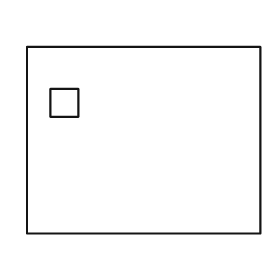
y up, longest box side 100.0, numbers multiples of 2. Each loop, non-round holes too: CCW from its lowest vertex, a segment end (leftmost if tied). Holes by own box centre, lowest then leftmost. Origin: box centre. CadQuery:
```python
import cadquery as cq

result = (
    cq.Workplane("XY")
    .moveTo(-50.0, -40.0)
    .lineTo(50.0, -40.0)
    .lineTo(50.0, 40.0)
    .lineTo(-50.0, 40.0)
    .close()
    .moveTo(-40.0, 10.0)
    .lineTo(-28.0, 10.0)
    .lineTo(-28.0, 22.0)
    .lineTo(-40.0, 22.0)
    .close()
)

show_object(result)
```